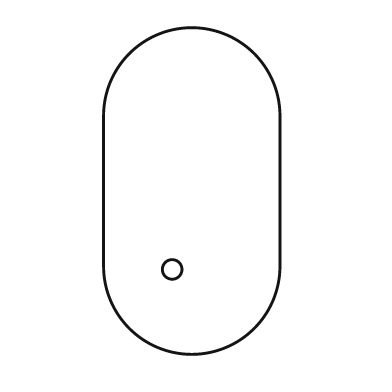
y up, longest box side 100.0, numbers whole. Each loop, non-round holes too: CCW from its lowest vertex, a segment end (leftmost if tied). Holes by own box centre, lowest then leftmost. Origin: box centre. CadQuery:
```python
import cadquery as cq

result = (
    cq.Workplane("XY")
    .moveTo(-27.0, -23.0)
    .threePointArc((0.0, -50.0), (27.0, -23.0))
    .lineTo(27.0, 23.0)
    .threePointArc((0.0, 50.0), (-27.0, 23.0))
    .close()
    .moveTo(-6.0, -24.0)
    .circle(3.0)
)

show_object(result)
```